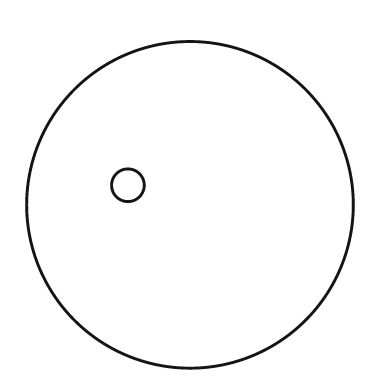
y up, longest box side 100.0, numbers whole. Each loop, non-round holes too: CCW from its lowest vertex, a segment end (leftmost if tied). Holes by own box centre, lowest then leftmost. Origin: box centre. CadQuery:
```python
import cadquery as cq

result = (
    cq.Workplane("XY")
    .moveTo(0.0, 0.0)
    .circle(50.0)
    .moveTo(-19.0, 6.0)
    .circle(5.0)
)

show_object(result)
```